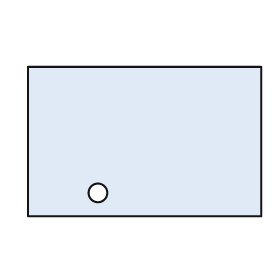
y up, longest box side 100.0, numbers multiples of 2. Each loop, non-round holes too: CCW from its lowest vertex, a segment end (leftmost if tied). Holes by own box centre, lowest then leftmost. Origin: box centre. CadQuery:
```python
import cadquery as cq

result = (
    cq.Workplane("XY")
    .moveTo(-50.0, -32.0)
    .lineTo(50.0, -32.0)
    .lineTo(50.0, 32.0)
    .lineTo(-50.0, 32.0)
    .close()
    .moveTo(-20.0, -22.0)
    .circle(4.0)
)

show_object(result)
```